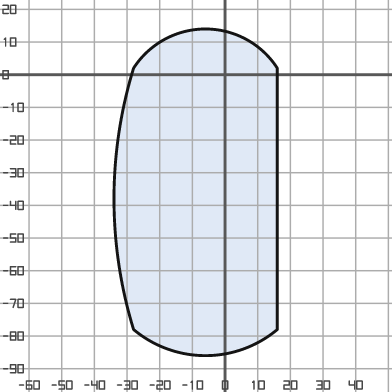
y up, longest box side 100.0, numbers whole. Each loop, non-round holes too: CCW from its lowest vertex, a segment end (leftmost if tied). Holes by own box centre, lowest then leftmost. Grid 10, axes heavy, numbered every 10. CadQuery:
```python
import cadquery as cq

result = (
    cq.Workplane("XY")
    .moveTo(-28.0, -78.0)
    .threePointArc((-6.0, -86.0), (16.0, -78.0))
    .lineTo(16.0, 2.0)
    .threePointArc((-6.0, 14.0), (-28.0, 2.0))
    .threePointArc((-34.0, -38.0), (-28.0, -78.0))
    .close()
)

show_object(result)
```